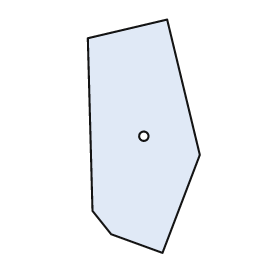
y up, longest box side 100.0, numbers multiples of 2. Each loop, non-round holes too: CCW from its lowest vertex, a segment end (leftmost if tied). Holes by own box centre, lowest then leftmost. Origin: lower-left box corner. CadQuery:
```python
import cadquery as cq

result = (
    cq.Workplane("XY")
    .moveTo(32.0, 0.0)
    .lineTo(48.0, 42.0)
    .lineTo(34.0, 100.0)
    .lineTo(0.0, 92.0)
    .lineTo(2.0, 18.0)
    .lineTo(10.0, 8.0)
    .close()
    .moveTo(24.0, 50.0)
    .circle(2.0)
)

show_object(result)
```